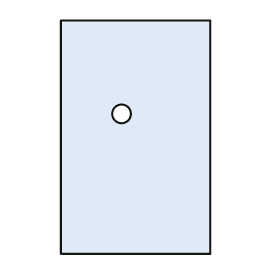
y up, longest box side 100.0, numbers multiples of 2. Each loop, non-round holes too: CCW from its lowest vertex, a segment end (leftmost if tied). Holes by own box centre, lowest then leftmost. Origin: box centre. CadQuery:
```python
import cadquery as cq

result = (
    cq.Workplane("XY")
    .moveTo(-32.0, -50.0)
    .lineTo(32.0, -50.0)
    .lineTo(32.0, 50.0)
    .lineTo(-32.0, 50.0)
    .close()
    .moveTo(-6.0, 10.0)
    .circle(4.0)
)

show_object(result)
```